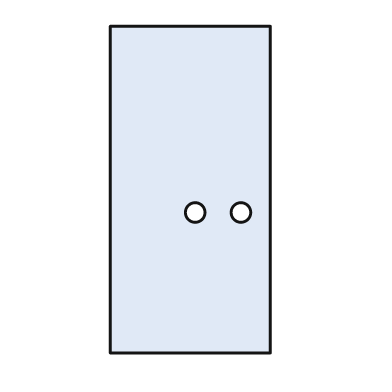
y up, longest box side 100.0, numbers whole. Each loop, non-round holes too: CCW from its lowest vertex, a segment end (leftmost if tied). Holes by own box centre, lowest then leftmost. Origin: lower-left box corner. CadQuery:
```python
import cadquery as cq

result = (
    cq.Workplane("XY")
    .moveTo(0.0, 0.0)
    .lineTo(49.0, 0.0)
    .lineTo(49.0, 100.0)
    .lineTo(0.0, 100.0)
    .close()
    .moveTo(26.0, 43.0)
    .circle(3.0)
    .moveTo(40.0, 43.0)
    .circle(3.0)
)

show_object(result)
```